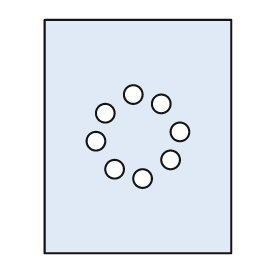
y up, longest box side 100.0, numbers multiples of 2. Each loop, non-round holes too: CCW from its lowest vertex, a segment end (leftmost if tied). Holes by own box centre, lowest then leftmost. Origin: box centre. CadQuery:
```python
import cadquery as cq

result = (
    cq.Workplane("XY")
    .moveTo(-40.0, -50.0)
    .lineTo(40.0, -50.0)
    .lineTo(40.0, 50.0)
    .lineTo(-40.0, 50.0)
    .close()
    .moveTo(2.0, -18.0)
    .circle(4.0)
    .moveTo(-10.0, -14.0)
    .circle(4.0)
    .moveTo(14.0, -10.0)
    .circle(4.0)
    .moveTo(-18.0, -2.0)
    .circle(4.0)
    .moveTo(18.0, 2.0)
    .circle(4.0)
    .moveTo(-14.0, 10.0)
    .circle(4.0)
    .moveTo(10.0, 14.0)
    .circle(4.0)
    .moveTo(-2.0, 18.0)
    .circle(4.0)
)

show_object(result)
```